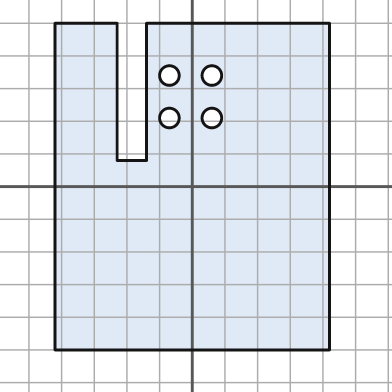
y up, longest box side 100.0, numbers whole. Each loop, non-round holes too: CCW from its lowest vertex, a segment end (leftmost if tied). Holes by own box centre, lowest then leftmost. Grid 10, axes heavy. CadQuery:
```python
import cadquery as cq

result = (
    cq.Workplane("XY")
    .moveTo(-42.0, -50.0)
    .lineTo(42.0, -50.0)
    .lineTo(42.0, 50.0)
    .lineTo(-14.0, 50.0)
    .lineTo(-14.0, 8.0)
    .lineTo(-23.0, 8.0)
    .lineTo(-23.0, 50.0)
    .lineTo(-42.0, 50.0)
    .close()
    .moveTo(-7.0, 21.0)
    .circle(3.0)
    .moveTo(6.0, 21.0)
    .circle(3.0)
    .moveTo(-7.0, 34.0)
    .circle(3.0)
    .moveTo(6.0, 34.0)
    .circle(3.0)
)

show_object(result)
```